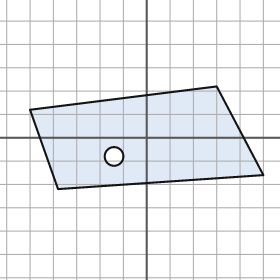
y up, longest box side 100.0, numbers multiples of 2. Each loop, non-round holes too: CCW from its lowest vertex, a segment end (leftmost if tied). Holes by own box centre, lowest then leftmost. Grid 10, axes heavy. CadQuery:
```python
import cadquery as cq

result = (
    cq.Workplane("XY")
    .moveTo(-38.0, -22.0)
    .lineTo(50.0, -16.0)
    .lineTo(30.0, 22.0)
    .lineTo(-50.0, 12.0)
    .close()
    .moveTo(-14.0, -8.0)
    .circle(4.0)
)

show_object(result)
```